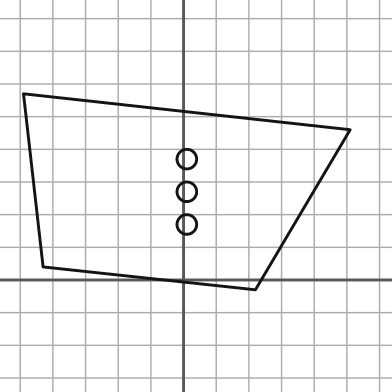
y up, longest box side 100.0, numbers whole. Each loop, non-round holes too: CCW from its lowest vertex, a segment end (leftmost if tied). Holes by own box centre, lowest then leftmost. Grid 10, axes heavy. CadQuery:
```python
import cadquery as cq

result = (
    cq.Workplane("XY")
    .moveTo(22.0, -3.0)
    .lineTo(51.0, 46.0)
    .lineTo(-49.0, 57.0)
    .lineTo(-43.0, 4.0)
    .close()
    .moveTo(1.0, 17.0)
    .circle(3.0)
    .moveTo(1.0, 27.0)
    .circle(3.0)
    .moveTo(1.0, 37.0)
    .circle(3.0)
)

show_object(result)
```